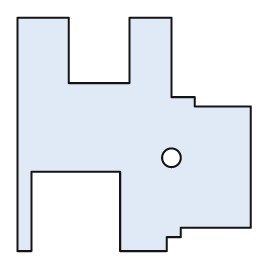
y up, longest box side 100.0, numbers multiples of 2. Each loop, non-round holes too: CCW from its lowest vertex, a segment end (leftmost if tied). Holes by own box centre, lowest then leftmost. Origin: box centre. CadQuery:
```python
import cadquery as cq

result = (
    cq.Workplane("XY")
    .moveTo(-50.0, -50.0)
    .lineTo(-44.0, -50.0)
    .lineTo(-44.0, -16.0)
    .lineTo(-6.0, -16.0)
    .lineTo(-6.0, -50.0)
    .lineTo(14.0, -50.0)
    .lineTo(14.0, -44.0)
    .lineTo(20.0, -44.0)
    .lineTo(20.0, -40.0)
    .lineTo(50.0, -40.0)
    .lineTo(50.0, 12.0)
    .lineTo(26.0, 12.0)
    .lineTo(26.0, 16.0)
    .lineTo(16.0, 16.0)
    .lineTo(16.0, 50.0)
    .lineTo(-2.0, 50.0)
    .lineTo(-2.0, 22.0)
    .lineTo(-28.0, 22.0)
    .lineTo(-28.0, 50.0)
    .lineTo(-50.0, 50.0)
    .close()
    .moveTo(16.0, -10.0)
    .circle(4.0)
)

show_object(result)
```